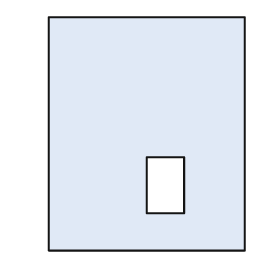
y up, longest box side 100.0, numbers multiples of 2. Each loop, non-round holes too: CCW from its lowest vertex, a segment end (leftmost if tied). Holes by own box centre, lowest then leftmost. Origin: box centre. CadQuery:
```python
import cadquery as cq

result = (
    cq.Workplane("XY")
    .moveTo(-42.0, -50.0)
    .lineTo(42.0, -50.0)
    .lineTo(42.0, 50.0)
    .lineTo(-42.0, 50.0)
    .close()
    .moveTo(0.0, -34.0)
    .lineTo(16.0, -34.0)
    .lineTo(16.0, -10.0)
    .lineTo(0.0, -10.0)
    .close()
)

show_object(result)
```